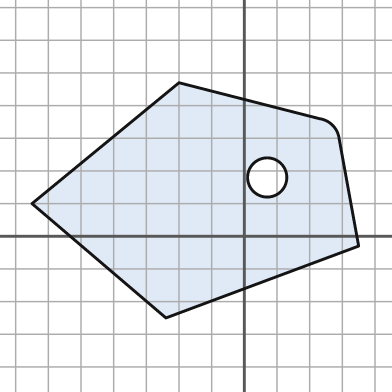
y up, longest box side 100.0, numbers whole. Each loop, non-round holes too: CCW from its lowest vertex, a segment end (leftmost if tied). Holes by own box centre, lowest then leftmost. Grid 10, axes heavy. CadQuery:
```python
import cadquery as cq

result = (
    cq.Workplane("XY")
    .moveTo(-24.0, -25.0)
    .lineTo(35.0, -3.0)
    .lineTo(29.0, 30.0)
    .threePointArc((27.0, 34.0), (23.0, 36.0))
    .lineTo(-20.0, 47.0)
    .lineTo(-65.0, 10.0)
    .close()
    .moveTo(7.0, 18.0)
    .circle(6.0)
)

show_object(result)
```